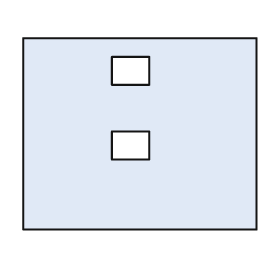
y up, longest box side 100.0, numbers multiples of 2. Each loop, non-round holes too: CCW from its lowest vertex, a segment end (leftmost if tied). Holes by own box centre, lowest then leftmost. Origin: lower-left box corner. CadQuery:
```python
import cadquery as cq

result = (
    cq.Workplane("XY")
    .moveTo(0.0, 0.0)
    .lineTo(100.0, 0.0)
    .lineTo(100.0, 82.0)
    .lineTo(0.0, 82.0)
    .close()
    .moveTo(38.0, 30.0)
    .lineTo(54.0, 30.0)
    .lineTo(54.0, 42.0)
    .lineTo(38.0, 42.0)
    .close()
    .moveTo(38.0, 62.0)
    .lineTo(54.0, 62.0)
    .lineTo(54.0, 74.0)
    .lineTo(38.0, 74.0)
    .close()
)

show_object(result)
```